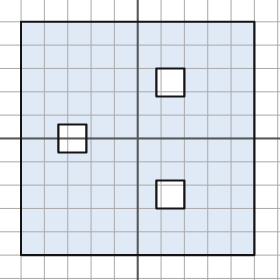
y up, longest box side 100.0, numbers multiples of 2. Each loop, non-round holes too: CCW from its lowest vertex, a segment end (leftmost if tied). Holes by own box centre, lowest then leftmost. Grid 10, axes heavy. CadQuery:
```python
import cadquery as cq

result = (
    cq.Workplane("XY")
    .moveTo(-50.0, -50.0)
    .lineTo(50.0, -50.0)
    .lineTo(50.0, 50.0)
    .lineTo(-50.0, 50.0)
    .close()
    .moveTo(8.0, -30.0)
    .lineTo(20.0, -30.0)
    .lineTo(20.0, -18.0)
    .lineTo(8.0, -18.0)
    .close()
    .moveTo(-34.0, -6.0)
    .lineTo(-22.0, -6.0)
    .lineTo(-22.0, 6.0)
    .lineTo(-34.0, 6.0)
    .close()
    .moveTo(8.0, 18.0)
    .lineTo(20.0, 18.0)
    .lineTo(20.0, 30.0)
    .lineTo(8.0, 30.0)
    .close()
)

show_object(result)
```